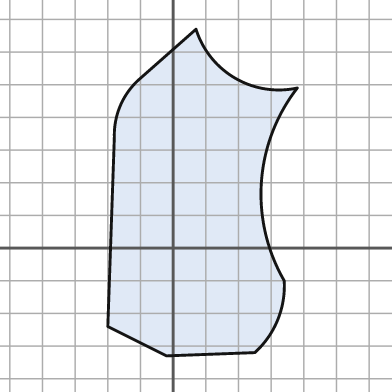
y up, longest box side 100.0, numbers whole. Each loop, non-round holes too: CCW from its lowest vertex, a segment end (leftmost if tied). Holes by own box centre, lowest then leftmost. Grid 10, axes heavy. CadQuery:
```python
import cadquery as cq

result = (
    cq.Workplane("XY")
    .moveTo(-2.0, -33.0)
    .lineTo(25.0, -32.0)
    .threePointArc((32.0, -22.0), (34.0, -10.0))
    .threePointArc((27.0, 20.0), (38.0, 49.0))
    .threePointArc((19.0, 52.0), (7.0, 67.0))
    .lineTo(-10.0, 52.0)
    .threePointArc((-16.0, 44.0), (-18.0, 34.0))
    .lineTo(-20.0, -24.0)
    .close()
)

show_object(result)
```